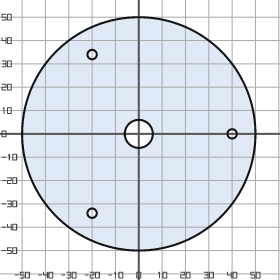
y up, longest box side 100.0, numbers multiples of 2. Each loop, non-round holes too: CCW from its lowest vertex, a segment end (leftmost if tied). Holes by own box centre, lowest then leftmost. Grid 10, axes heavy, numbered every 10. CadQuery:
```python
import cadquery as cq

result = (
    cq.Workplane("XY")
    .moveTo(0.0, 0.0)
    .circle(50.0)
    .moveTo(-20.0, -34.0)
    .circle(2.0)
    .moveTo(0.0, 0.0)
    .circle(6.0)
    .moveTo(40.0, 0.0)
    .circle(2.0)
    .moveTo(-20.0, 34.0)
    .circle(2.0)
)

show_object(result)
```